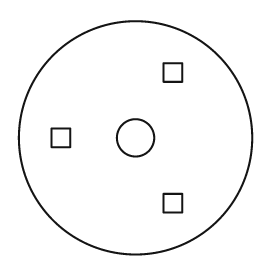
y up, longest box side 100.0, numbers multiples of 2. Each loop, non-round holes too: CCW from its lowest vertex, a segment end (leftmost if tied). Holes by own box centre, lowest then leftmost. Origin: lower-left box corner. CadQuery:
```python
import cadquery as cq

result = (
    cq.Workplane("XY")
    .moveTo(50.0, 50.0)
    .circle(50.0)
    .moveTo(62.0, 18.0)
    .lineTo(70.0, 18.0)
    .lineTo(70.0, 26.0)
    .lineTo(62.0, 26.0)
    .close()
    .moveTo(14.0, 46.0)
    .lineTo(22.0, 46.0)
    .lineTo(22.0, 54.0)
    .lineTo(14.0, 54.0)
    .close()
    .moveTo(50.0, 50.0)
    .circle(8.0)
    .moveTo(62.0, 74.0)
    .lineTo(70.0, 74.0)
    .lineTo(70.0, 82.0)
    .lineTo(62.0, 82.0)
    .close()
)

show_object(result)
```